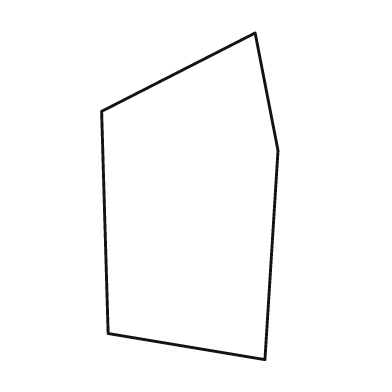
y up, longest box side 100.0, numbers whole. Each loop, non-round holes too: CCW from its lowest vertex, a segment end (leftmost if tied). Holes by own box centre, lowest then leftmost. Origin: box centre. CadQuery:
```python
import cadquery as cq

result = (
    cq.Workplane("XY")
    .moveTo(23.0, -50.0)
    .lineTo(27.0, 14.0)
    .lineTo(20.0, 50.0)
    .lineTo(-27.0, 26.0)
    .lineTo(-25.0, -42.0)
    .close()
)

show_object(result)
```